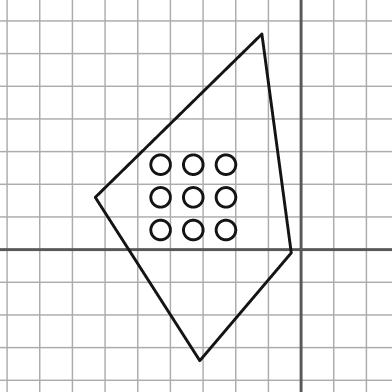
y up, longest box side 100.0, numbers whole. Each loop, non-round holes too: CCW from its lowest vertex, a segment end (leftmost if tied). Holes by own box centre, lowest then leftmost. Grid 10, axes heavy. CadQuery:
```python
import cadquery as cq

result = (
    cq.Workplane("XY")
    .moveTo(-31.0, -34.0)
    .lineTo(-3.0, -1.0)
    .lineTo(-12.0, 66.0)
    .lineTo(-63.0, 16.0)
    .close()
    .moveTo(-43.0, 6.0)
    .circle(3.0)
    .moveTo(-33.0, 6.0)
    .circle(3.0)
    .moveTo(-23.0, 6.0)
    .circle(3.0)
    .moveTo(-43.0, 16.0)
    .circle(3.0)
    .moveTo(-33.0, 16.0)
    .circle(3.0)
    .moveTo(-23.0, 16.0)
    .circle(3.0)
    .moveTo(-43.0, 26.0)
    .circle(3.0)
    .moveTo(-33.0, 26.0)
    .circle(3.0)
    .moveTo(-23.0, 26.0)
    .circle(3.0)
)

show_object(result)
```